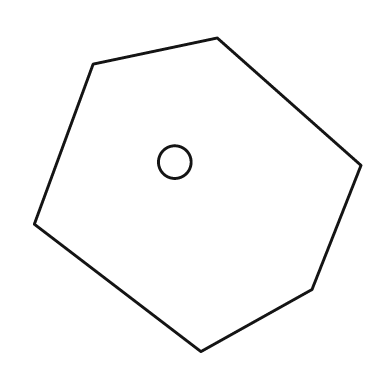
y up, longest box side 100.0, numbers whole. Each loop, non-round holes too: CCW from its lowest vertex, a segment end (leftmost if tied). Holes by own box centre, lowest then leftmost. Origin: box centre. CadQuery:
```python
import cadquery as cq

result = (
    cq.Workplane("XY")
    .moveTo(1.0, -48.0)
    .lineTo(35.0, -29.0)
    .lineTo(50.0, 9.0)
    .lineTo(6.0, 48.0)
    .lineTo(-32.0, 40.0)
    .lineTo(-50.0, -9.0)
    .close()
    .moveTo(-7.0, 10.0)
    .circle(5.0)
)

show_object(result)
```